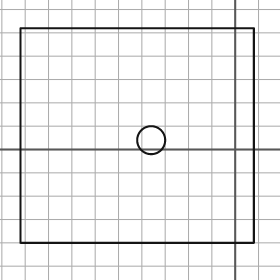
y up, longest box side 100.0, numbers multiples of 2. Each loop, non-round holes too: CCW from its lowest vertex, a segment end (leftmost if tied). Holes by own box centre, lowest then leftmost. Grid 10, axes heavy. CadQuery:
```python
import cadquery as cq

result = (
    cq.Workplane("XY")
    .moveTo(-92.0, -40.0)
    .lineTo(8.0, -40.0)
    .lineTo(8.0, 52.0)
    .lineTo(-92.0, 52.0)
    .close()
    .moveTo(-36.0, 4.0)
    .circle(6.0)
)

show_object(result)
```